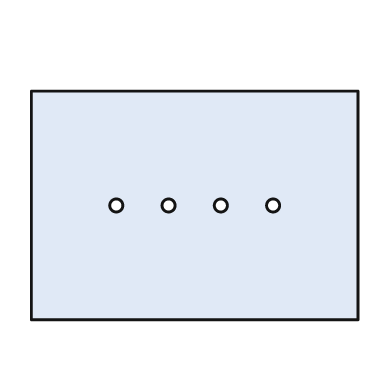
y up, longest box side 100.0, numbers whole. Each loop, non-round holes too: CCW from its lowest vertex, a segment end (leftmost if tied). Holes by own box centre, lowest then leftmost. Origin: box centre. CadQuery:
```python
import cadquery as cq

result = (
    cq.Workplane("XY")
    .moveTo(-50.0, -35.0)
    .lineTo(50.0, -35.0)
    .lineTo(50.0, 35.0)
    .lineTo(-50.0, 35.0)
    .close()
    .moveTo(-24.0, 0.0)
    .circle(2.0)
    .moveTo(-8.0, 0.0)
    .circle(2.0)
    .moveTo(8.0, 0.0)
    .circle(2.0)
    .moveTo(24.0, 0.0)
    .circle(2.0)
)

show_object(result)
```